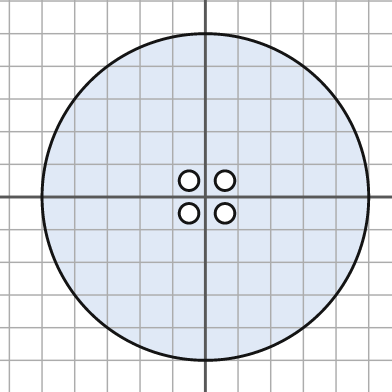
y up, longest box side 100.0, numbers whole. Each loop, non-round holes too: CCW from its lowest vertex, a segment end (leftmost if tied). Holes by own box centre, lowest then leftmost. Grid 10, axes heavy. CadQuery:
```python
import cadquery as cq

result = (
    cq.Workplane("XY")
    .moveTo(0.0, 0.0)
    .circle(50.0)
    .moveTo(-5.0, -5.0)
    .circle(3.0)
    .moveTo(6.0, -5.0)
    .circle(3.0)
    .moveTo(-5.0, 5.0)
    .circle(3.0)
    .moveTo(6.0, 5.0)
    .circle(3.0)
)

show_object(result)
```